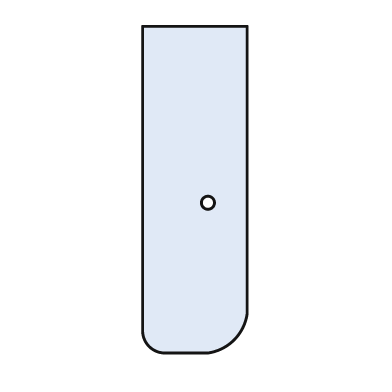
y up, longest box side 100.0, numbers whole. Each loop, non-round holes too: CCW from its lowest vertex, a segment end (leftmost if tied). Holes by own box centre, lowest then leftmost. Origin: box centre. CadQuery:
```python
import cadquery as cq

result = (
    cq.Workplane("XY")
    .moveTo(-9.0, -50.0)
    .lineTo(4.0, -50.0)
    .threePointArc((12.0, -46.0), (16.0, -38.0))
    .lineTo(16.0, 50.0)
    .lineTo(-16.0, 50.0)
    .lineTo(-16.0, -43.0)
    .threePointArc((-14.0, -48.0), (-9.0, -50.0))
    .close()
    .moveTo(4.0, -4.0)
    .circle(2.0)
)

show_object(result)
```